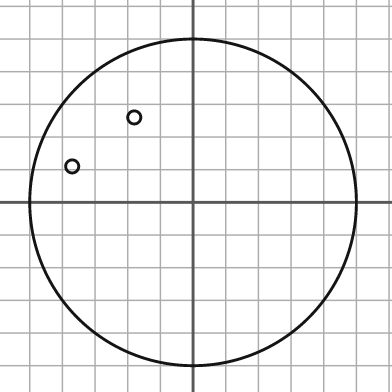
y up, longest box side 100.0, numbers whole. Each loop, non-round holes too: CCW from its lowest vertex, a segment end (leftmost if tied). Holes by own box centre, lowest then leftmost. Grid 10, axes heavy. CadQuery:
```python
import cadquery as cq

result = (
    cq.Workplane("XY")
    .moveTo(0.0, 0.0)
    .circle(50.0)
    .moveTo(-37.0, 11.0)
    .circle(2.0)
    .moveTo(-18.0, 26.0)
    .circle(2.0)
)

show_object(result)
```